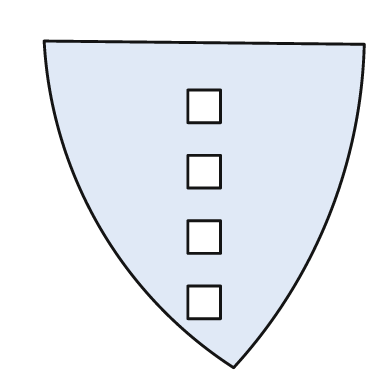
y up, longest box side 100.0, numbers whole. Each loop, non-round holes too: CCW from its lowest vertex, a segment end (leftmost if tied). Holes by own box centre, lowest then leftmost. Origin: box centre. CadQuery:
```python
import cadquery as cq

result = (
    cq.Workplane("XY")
    .moveTo(9.0, -50.0)
    .threePointArc((38.0, -4.0), (49.0, 49.0))
    .lineTo(-49.0, 50.0)
    .threePointArc((-32.0, -7.0), (9.0, -50.0))
    .close()
    .moveTo(-5.0, -35.0)
    .lineTo(5.0, -35.0)
    .lineTo(5.0, -25.0)
    .lineTo(-5.0, -25.0)
    .close()
    .moveTo(-5.0, -15.0)
    .lineTo(5.0, -15.0)
    .lineTo(5.0, -5.0)
    .lineTo(-5.0, -5.0)
    .close()
    .moveTo(-5.0, 5.0)
    .lineTo(5.0, 5.0)
    .lineTo(5.0, 15.0)
    .lineTo(-5.0, 15.0)
    .close()
    .moveTo(-5.0, 25.0)
    .lineTo(5.0, 25.0)
    .lineTo(5.0, 35.0)
    .lineTo(-5.0, 35.0)
    .close()
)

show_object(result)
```